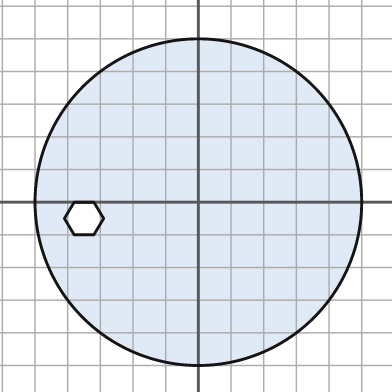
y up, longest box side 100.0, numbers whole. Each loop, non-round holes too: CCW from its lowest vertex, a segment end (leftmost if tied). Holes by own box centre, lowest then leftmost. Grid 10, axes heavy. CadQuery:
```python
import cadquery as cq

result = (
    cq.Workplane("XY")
    .moveTo(0.0, 0.0)
    .circle(50.0)
    .moveTo(-38.0, -10.0)
    .lineTo(-32.0, -10.0)
    .lineTo(-29.0, -5.0)
    .lineTo(-32.0, 0.0)
    .lineTo(-38.0, 0.0)
    .lineTo(-41.0, -5.0)
    .close()
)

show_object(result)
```